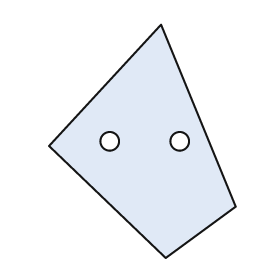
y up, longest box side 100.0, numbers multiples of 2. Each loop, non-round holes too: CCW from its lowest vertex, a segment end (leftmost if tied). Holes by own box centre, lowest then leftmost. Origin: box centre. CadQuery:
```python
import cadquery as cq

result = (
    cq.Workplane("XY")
    .moveTo(10.0, -50.0)
    .lineTo(40.0, -28.0)
    .lineTo(8.0, 50.0)
    .lineTo(-40.0, -2.0)
    .close()
    .moveTo(-14.0, 0.0)
    .circle(4.0)
    .moveTo(16.0, 0.0)
    .circle(4.0)
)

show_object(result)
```